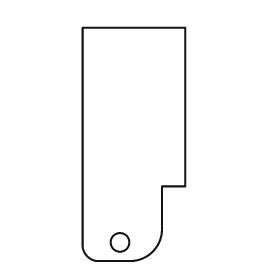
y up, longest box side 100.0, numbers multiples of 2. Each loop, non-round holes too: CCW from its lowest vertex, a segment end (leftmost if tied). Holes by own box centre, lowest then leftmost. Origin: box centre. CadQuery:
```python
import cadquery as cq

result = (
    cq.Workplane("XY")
    .moveTo(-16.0, -50.0)
    .lineTo(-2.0, -50.0)
    .threePointArc((8.0, -46.0), (12.0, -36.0))
    .lineTo(12.0, -18.0)
    .lineTo(22.0, -18.0)
    .lineTo(22.0, 50.0)
    .lineTo(-22.0, 50.0)
    .lineTo(-22.0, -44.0)
    .threePointArc((-20.0, -48.0), (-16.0, -50.0))
    .close()
    .moveTo(-6.0, -42.0)
    .circle(4.0)
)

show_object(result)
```